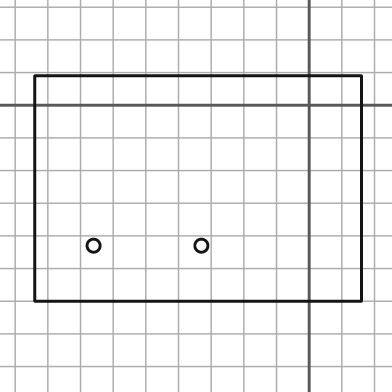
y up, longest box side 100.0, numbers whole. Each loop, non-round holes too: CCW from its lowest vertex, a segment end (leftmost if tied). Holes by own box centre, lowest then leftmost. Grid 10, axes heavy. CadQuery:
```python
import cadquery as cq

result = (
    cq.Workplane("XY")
    .moveTo(-84.0, -60.0)
    .lineTo(16.0, -60.0)
    .lineTo(16.0, 9.0)
    .lineTo(-84.0, 9.0)
    .close()
    .moveTo(-66.0, -43.0)
    .circle(2.0)
    .moveTo(-33.0, -43.0)
    .circle(2.0)
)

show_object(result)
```